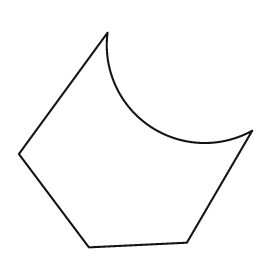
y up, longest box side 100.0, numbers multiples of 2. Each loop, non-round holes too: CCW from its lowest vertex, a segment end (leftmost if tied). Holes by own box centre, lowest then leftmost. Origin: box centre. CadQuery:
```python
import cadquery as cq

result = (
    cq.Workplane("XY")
    .moveTo(-20.0, -46.0)
    .lineTo(22.0, -44.0)
    .lineTo(50.0, 4.0)
    .threePointArc((6.0, 6.0), (-12.0, 46.0))
    .lineTo(-50.0, -6.0)
    .close()
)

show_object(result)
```